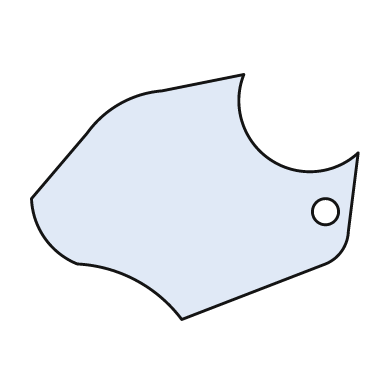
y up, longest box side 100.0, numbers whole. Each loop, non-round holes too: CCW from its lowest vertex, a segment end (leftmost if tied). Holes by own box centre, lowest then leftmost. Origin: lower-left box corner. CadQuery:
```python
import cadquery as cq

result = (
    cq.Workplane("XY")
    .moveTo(46.0, 0.0)
    .lineTo(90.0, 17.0)
    .threePointArc((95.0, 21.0), (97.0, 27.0))
    .lineTo(100.0, 51.0)
    .threePointArc((73.0, 49.0), (65.0, 75.0))
    .lineTo(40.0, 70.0)
    .threePointArc((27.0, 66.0), (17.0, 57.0))
    .lineTo(0.0, 37.0)
    .threePointArc((4.0, 25.0), (14.0, 17.0))
    .threePointArc((32.0, 12.0), (46.0, 0.0))
    .close()
    .moveTo(90.0, 33.0)
    .circle(4.0)
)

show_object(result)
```